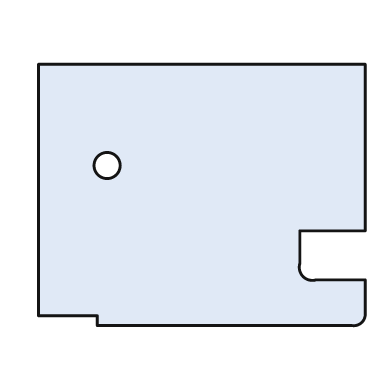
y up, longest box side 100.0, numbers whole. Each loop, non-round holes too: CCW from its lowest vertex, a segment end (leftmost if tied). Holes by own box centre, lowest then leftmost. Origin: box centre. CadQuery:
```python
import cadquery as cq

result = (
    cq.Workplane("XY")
    .moveTo(-32.0, -40.0)
    .lineTo(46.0, -40.0)
    .threePointArc((49.0, -39.0), (50.0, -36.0))
    .lineTo(50.0, -26.0)
    .lineTo(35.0, -26.0)
    .threePointArc((31.0, -25.0), (30.0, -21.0))
    .lineTo(30.0, -11.0)
    .lineTo(50.0, -11.0)
    .lineTo(50.0, 40.0)
    .lineTo(-50.0, 40.0)
    .lineTo(-50.0, -37.0)
    .lineTo(-32.0, -37.0)
    .close()
    .moveTo(-29.0, 9.0)
    .circle(4.0)
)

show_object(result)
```